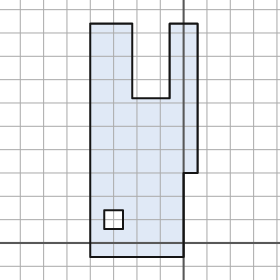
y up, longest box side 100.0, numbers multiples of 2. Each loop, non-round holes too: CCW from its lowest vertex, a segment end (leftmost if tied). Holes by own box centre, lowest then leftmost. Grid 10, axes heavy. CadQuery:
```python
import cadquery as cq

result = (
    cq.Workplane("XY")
    .moveTo(-40.0, -6.0)
    .lineTo(0.0, -6.0)
    .lineTo(0.0, 30.0)
    .lineTo(6.0, 30.0)
    .lineTo(6.0, 94.0)
    .lineTo(-6.0, 94.0)
    .lineTo(-6.0, 62.0)
    .lineTo(-22.0, 62.0)
    .lineTo(-22.0, 94.0)
    .lineTo(-40.0, 94.0)
    .close()
    .moveTo(-34.0, 6.0)
    .lineTo(-26.0, 6.0)
    .lineTo(-26.0, 14.0)
    .lineTo(-34.0, 14.0)
    .close()
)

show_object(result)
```